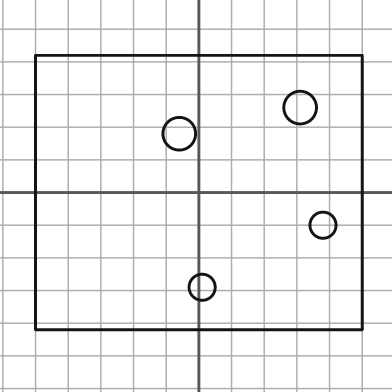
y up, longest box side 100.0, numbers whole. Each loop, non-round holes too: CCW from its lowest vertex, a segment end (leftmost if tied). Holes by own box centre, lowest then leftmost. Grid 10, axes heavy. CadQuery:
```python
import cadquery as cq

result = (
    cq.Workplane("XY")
    .moveTo(-50.0, -42.0)
    .lineTo(50.0, -42.0)
    .lineTo(50.0, 42.0)
    .lineTo(-50.0, 42.0)
    .close()
    .moveTo(1.0, -29.0)
    .circle(4.0)
    .moveTo(38.0, -10.0)
    .circle(4.0)
    .moveTo(-6.0, 18.0)
    .circle(5.0)
    .moveTo(31.0, 26.0)
    .circle(5.0)
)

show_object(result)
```